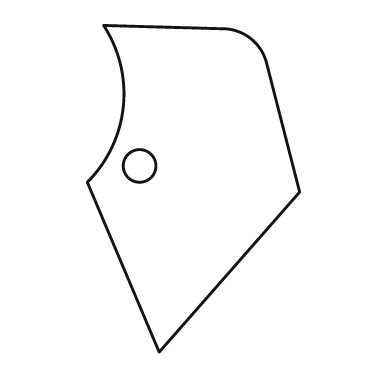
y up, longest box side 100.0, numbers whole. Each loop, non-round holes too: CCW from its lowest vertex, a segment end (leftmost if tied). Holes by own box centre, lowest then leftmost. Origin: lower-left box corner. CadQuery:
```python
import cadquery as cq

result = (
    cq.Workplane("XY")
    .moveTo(22.0, 0.0)
    .lineTo(65.0, 49.0)
    .lineTo(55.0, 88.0)
    .threePointArc((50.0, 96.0), (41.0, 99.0))
    .lineTo(5.0, 100.0)
    .threePointArc((11.0, 75.0), (0.0, 52.0))
    .close()
    .moveTo(16.0, 57.0)
    .circle(5.0)
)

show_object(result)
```